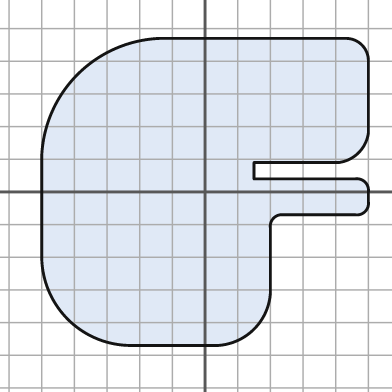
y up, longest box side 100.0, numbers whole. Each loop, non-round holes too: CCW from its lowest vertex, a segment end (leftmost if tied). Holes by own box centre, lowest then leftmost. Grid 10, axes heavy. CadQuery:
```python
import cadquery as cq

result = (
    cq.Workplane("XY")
    .moveTo(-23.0, -47.0)
    .lineTo(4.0, -47.0)
    .threePointArc((15.0, -42.0), (20.0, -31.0))
    .lineTo(20.0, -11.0)
    .threePointArc((21.0, -8.0), (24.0, -7.0))
    .lineTo(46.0, -7.0)
    .threePointArc((49.0, -6.0), (50.0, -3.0))
    .lineTo(50.0, 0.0)
    .threePointArc((49.0, 3.0), (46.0, 4.0))
    .lineTo(15.0, 4.0)
    .lineTo(15.0, 9.0)
    .lineTo(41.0, 9.0)
    .threePointArc((47.0, 12.0), (50.0, 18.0))
    .lineTo(50.0, 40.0)
    .threePointArc((48.0, 45.0), (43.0, 47.0))
    .lineTo(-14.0, 47.0)
    .threePointArc((-39.0, 36.0), (-50.0, 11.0))
    .lineTo(-50.0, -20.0)
    .threePointArc((-42.0, -39.0), (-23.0, -47.0))
    .close()
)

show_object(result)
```